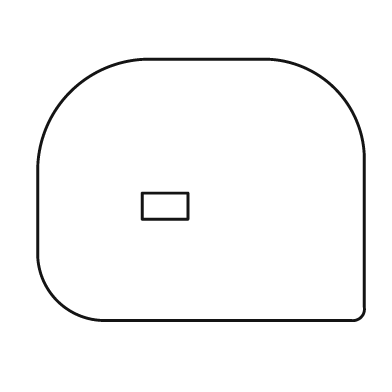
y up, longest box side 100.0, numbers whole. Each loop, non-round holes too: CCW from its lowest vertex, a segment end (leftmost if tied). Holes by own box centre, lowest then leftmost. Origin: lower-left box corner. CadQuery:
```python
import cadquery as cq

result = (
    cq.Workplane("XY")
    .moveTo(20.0, 0.0)
    .lineTo(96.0, 0.0)
    .threePointArc((99.0, 1.0), (100.0, 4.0))
    .lineTo(100.0, 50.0)
    .threePointArc((91.0, 71.0), (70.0, 80.0))
    .lineTo(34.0, 80.0)
    .threePointArc((10.0, 70.0), (0.0, 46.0))
    .lineTo(0.0, 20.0)
    .threePointArc((6.0, 6.0), (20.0, 0.0))
    .close()
    .moveTo(32.0, 31.0)
    .lineTo(46.0, 31.0)
    .lineTo(46.0, 39.0)
    .lineTo(32.0, 39.0)
    .close()
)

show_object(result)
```